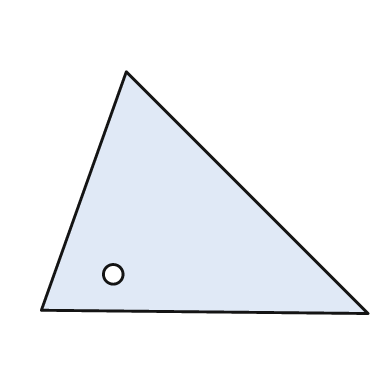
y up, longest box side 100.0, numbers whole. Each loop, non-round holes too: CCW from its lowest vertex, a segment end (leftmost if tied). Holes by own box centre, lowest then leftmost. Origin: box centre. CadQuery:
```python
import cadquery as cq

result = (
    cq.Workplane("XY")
    .moveTo(50.0, -37.0)
    .lineTo(-24.0, 37.0)
    .lineTo(-50.0, -36.0)
    .close()
    .moveTo(-28.0, -25.0)
    .circle(3.0)
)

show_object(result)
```